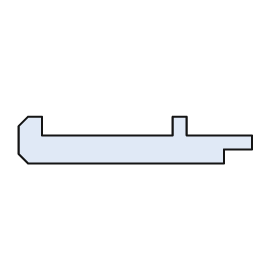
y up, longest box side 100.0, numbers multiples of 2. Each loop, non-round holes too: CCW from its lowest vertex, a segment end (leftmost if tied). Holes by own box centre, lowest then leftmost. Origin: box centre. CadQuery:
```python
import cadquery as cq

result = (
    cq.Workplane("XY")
    .moveTo(-46.0, -10.0)
    .lineTo(38.0, -10.0)
    .lineTo(38.0, -4.0)
    .lineTo(50.0, -4.0)
    .lineTo(50.0, 2.0)
    .lineTo(22.0, 2.0)
    .lineTo(22.0, 10.0)
    .lineTo(16.0, 10.0)
    .lineTo(16.0, 2.0)
    .lineTo(-40.0, 2.0)
    .lineTo(-40.0, 10.0)
    .lineTo(-46.0, 10.0)
    .lineTo(-50.0, 6.0)
    .lineTo(-50.0, -6.0)
    .close()
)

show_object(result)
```